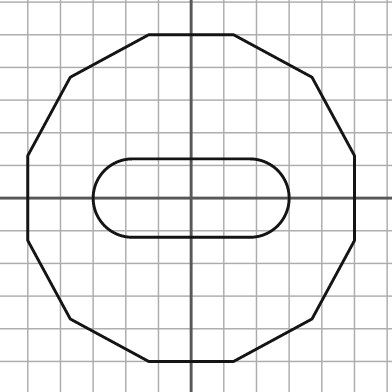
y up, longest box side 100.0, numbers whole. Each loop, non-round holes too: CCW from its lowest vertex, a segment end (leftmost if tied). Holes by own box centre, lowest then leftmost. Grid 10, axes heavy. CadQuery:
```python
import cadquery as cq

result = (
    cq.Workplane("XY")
    .moveTo(-13.0, -50.0)
    .lineTo(13.0, -50.0)
    .lineTo(37.0, -37.0)
    .lineTo(50.0, -13.0)
    .lineTo(50.0, 13.0)
    .lineTo(37.0, 37.0)
    .lineTo(13.0, 50.0)
    .lineTo(-13.0, 50.0)
    .lineTo(-37.0, 37.0)
    .lineTo(-50.0, 13.0)
    .lineTo(-50.0, -13.0)
    .lineTo(-37.0, -37.0)
    .close()
    .moveTo(-18.0, -12.0)
    .lineTo(18.0, -12.0)
    .threePointArc((30.0, 0.0), (18.0, 12.0))
    .lineTo(-18.0, 12.0)
    .threePointArc((-30.0, 0.0), (-18.0, -12.0))
    .close()
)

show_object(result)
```